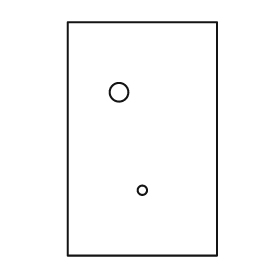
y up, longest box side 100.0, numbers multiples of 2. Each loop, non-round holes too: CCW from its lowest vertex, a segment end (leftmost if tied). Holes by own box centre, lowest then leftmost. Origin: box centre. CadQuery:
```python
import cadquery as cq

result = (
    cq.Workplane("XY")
    .moveTo(-32.0, -50.0)
    .lineTo(32.0, -50.0)
    .lineTo(32.0, 50.0)
    .lineTo(-32.0, 50.0)
    .close()
    .moveTo(0.0, -22.0)
    .circle(2.0)
    .moveTo(-10.0, 20.0)
    .circle(4.0)
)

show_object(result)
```